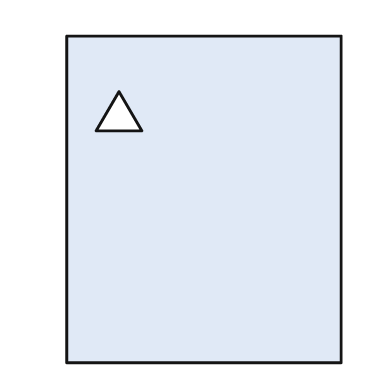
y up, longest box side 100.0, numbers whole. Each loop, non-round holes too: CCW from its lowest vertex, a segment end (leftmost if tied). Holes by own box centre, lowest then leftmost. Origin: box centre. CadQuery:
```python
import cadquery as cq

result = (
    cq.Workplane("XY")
    .moveTo(-42.0, -50.0)
    .lineTo(42.0, -50.0)
    .lineTo(42.0, 50.0)
    .lineTo(-42.0, 50.0)
    .close()
    .moveTo(-33.0, 21.0)
    .lineTo(-19.0, 21.0)
    .lineTo(-26.0, 33.0)
    .close()
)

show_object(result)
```